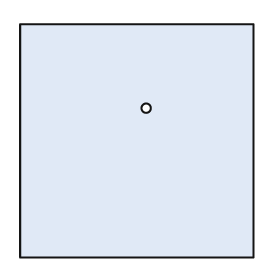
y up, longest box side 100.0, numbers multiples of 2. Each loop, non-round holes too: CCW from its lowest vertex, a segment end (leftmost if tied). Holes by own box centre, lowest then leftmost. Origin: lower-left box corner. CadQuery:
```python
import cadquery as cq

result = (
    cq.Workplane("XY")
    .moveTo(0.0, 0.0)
    .lineTo(100.0, 0.0)
    .lineTo(100.0, 100.0)
    .lineTo(0.0, 100.0)
    .close()
    .moveTo(54.0, 64.0)
    .circle(2.0)
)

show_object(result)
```